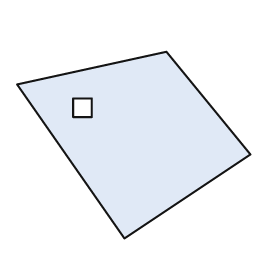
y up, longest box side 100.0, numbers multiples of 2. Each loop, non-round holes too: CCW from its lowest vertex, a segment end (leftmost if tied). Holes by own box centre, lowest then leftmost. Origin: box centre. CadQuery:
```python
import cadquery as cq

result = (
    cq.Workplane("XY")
    .moveTo(-4.0, -40.0)
    .lineTo(50.0, -4.0)
    .lineTo(14.0, 40.0)
    .lineTo(-50.0, 26.0)
    .close()
    .moveTo(-26.0, 12.0)
    .lineTo(-18.0, 12.0)
    .lineTo(-18.0, 20.0)
    .lineTo(-26.0, 20.0)
    .close()
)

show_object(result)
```